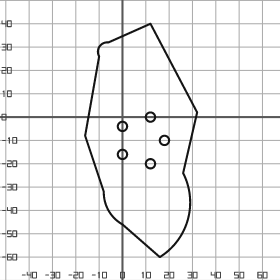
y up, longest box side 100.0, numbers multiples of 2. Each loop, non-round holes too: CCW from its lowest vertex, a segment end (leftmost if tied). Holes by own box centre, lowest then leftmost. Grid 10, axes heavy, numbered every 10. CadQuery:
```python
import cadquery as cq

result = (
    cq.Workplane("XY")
    .moveTo(16.0, -60.0)
    .threePointArc((28.0, -44.0), (26.0, -24.0))
    .lineTo(32.0, 2.0)
    .lineTo(12.0, 40.0)
    .lineTo(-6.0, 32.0)
    .threePointArc((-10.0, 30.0), (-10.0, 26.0))
    .lineTo(-16.0, -8.0)
    .lineTo(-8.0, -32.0)
    .threePointArc((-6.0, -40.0), (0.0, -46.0))
    .close()
    .moveTo(12.0, -20.0)
    .circle(2.0)
    .moveTo(0.0, -16.0)
    .circle(2.0)
    .moveTo(18.0, -10.0)
    .circle(2.0)
    .moveTo(0.0, -4.0)
    .circle(2.0)
    .moveTo(12.0, 0.0)
    .circle(2.0)
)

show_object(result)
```